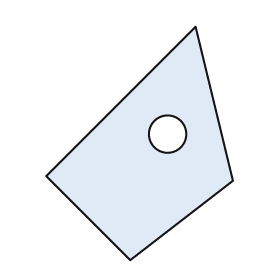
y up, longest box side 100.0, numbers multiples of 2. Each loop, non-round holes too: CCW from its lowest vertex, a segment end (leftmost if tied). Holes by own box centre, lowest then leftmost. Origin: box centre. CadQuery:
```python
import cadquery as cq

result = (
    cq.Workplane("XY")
    .moveTo(-4.0, -50.0)
    .lineTo(40.0, -16.0)
    .lineTo(24.0, 50.0)
    .lineTo(-40.0, -14.0)
    .close()
    .moveTo(12.0, 4.0)
    .circle(8.0)
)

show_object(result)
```